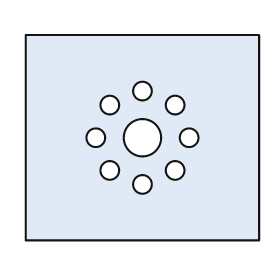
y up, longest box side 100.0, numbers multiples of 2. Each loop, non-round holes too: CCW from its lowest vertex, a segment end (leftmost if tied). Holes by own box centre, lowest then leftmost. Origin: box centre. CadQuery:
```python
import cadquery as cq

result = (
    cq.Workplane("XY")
    .moveTo(-50.0, -44.0)
    .lineTo(50.0, -44.0)
    .lineTo(50.0, 44.0)
    .lineTo(-50.0, 44.0)
    .close()
    .moveTo(0.0, -20.0)
    .circle(4.0)
    .moveTo(-14.0, -14.0)
    .circle(4.0)
    .moveTo(14.0, -14.0)
    .circle(4.0)
    .moveTo(-20.0, 0.0)
    .circle(4.0)
    .moveTo(0.0, 0.0)
    .circle(8.0)
    .moveTo(20.0, 0.0)
    .circle(4.0)
    .moveTo(-14.0, 14.0)
    .circle(4.0)
    .moveTo(14.0, 14.0)
    .circle(4.0)
    .moveTo(0.0, 20.0)
    .circle(4.0)
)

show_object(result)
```